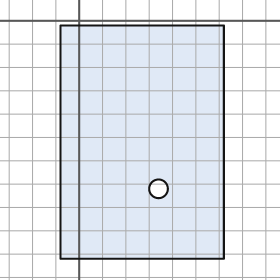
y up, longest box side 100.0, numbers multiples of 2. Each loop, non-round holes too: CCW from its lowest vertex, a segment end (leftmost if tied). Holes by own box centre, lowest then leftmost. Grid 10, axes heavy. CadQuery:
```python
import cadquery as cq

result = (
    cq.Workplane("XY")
    .moveTo(-8.0, -102.0)
    .lineTo(62.0, -102.0)
    .lineTo(62.0, -2.0)
    .lineTo(-8.0, -2.0)
    .close()
    .moveTo(34.0, -72.0)
    .circle(4.0)
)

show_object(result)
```